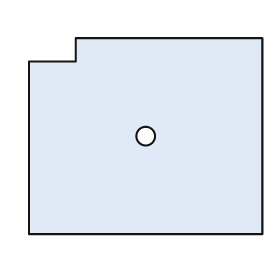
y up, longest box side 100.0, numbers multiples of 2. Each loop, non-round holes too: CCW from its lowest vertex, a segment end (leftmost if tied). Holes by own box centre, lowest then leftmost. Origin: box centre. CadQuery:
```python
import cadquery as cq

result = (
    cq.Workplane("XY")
    .moveTo(-50.0, -42.0)
    .lineTo(50.0, -42.0)
    .lineTo(50.0, 42.0)
    .lineTo(-30.0, 42.0)
    .lineTo(-30.0, 32.0)
    .lineTo(-50.0, 32.0)
    .close()
    .moveTo(0.0, 0.0)
    .circle(4.0)
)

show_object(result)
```